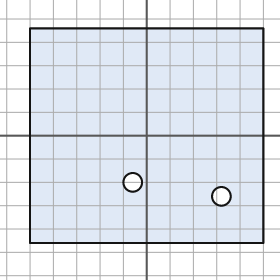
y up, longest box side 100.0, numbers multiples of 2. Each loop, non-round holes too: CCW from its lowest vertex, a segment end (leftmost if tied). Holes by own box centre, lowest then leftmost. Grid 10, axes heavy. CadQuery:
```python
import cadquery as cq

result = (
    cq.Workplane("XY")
    .moveTo(-50.0, -46.0)
    .lineTo(50.0, -46.0)
    .lineTo(50.0, 46.0)
    .lineTo(-50.0, 46.0)
    .close()
    .moveTo(32.0, -26.0)
    .circle(4.0)
    .moveTo(-6.0, -20.0)
    .circle(4.0)
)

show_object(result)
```